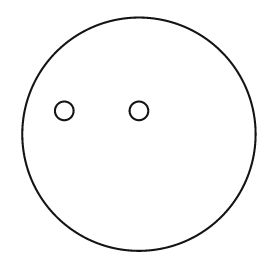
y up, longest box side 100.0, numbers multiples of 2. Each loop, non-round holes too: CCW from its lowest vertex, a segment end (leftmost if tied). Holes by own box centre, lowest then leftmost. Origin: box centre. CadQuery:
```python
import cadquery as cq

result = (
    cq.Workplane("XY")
    .moveTo(0.0, 0.0)
    .circle(50.0)
    .moveTo(-32.0, 10.0)
    .circle(4.0)
    .moveTo(0.0, 10.0)
    .circle(4.0)
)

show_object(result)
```